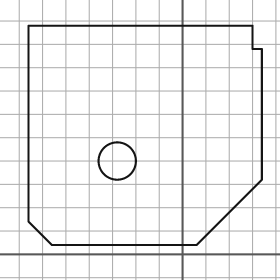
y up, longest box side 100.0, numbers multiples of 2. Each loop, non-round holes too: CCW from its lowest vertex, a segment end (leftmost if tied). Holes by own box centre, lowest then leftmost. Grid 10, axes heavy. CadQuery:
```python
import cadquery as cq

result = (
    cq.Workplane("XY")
    .moveTo(-56.0, 4.0)
    .lineTo(6.0, 4.0)
    .lineTo(34.0, 32.0)
    .lineTo(34.0, 88.0)
    .lineTo(30.0, 88.0)
    .lineTo(30.0, 98.0)
    .lineTo(-66.0, 98.0)
    .lineTo(-66.0, 14.0)
    .close()
    .moveTo(-28.0, 40.0)
    .circle(8.0)
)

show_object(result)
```